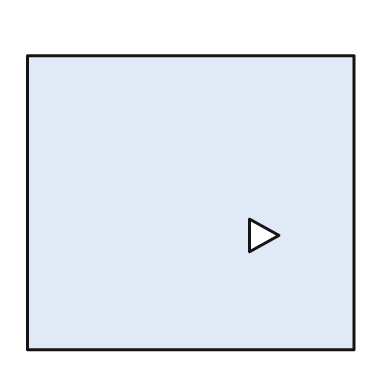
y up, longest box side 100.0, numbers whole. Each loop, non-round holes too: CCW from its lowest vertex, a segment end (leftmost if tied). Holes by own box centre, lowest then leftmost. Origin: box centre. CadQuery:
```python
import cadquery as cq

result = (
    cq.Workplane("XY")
    .moveTo(-50.0, -45.0)
    .lineTo(50.0, -45.0)
    .lineTo(50.0, 45.0)
    .lineTo(-50.0, 45.0)
    .close()
    .moveTo(18.0, -15.0)
    .lineTo(27.0, -10.0)
    .lineTo(18.0, -5.0)
    .close()
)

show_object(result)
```